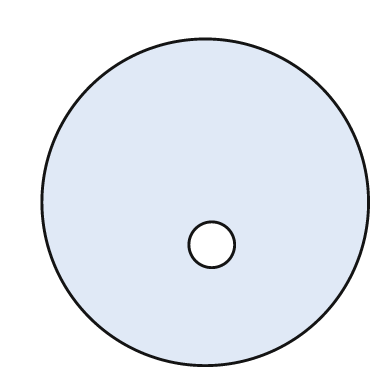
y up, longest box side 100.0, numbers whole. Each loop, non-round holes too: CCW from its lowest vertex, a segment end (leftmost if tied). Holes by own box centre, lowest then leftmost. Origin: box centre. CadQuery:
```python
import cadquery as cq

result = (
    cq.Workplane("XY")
    .moveTo(0.0, 0.0)
    .circle(50.0)
    .moveTo(2.0, -13.0)
    .circle(7.0)
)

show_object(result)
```